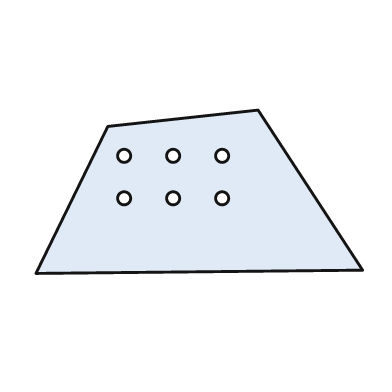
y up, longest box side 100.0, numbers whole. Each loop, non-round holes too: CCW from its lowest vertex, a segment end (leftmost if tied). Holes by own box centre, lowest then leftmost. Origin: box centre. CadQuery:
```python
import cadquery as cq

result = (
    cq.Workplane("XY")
    .moveTo(-50.0, -25.0)
    .lineTo(50.0, -24.0)
    .lineTo(18.0, 25.0)
    .lineTo(-28.0, 20.0)
    .close()
    .moveTo(-23.0, -2.0)
    .circle(2.0)
    .moveTo(-8.0, -2.0)
    .circle(2.0)
    .moveTo(7.0, -2.0)
    .circle(2.0)
    .moveTo(-23.0, 11.0)
    .circle(2.0)
    .moveTo(-8.0, 11.0)
    .circle(2.0)
    .moveTo(7.0, 11.0)
    .circle(2.0)
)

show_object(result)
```